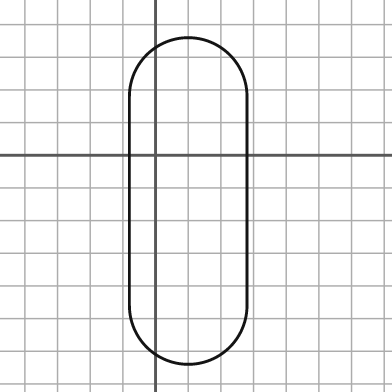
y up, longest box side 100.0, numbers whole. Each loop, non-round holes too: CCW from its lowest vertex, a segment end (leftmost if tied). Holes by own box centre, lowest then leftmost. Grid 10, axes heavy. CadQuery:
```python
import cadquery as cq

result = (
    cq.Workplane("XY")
    .moveTo(-8.0, -46.0)
    .threePointArc((10.0, -64.0), (28.0, -46.0))
    .lineTo(28.0, 18.0)
    .threePointArc((10.0, 36.0), (-8.0, 18.0))
    .close()
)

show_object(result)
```